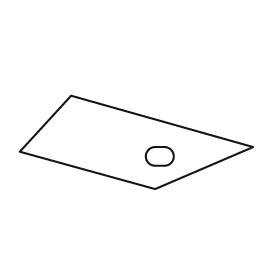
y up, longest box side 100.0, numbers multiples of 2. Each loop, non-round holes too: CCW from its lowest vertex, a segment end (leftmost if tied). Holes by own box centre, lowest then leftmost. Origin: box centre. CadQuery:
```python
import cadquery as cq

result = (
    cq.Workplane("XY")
    .moveTo(8.0, -20.0)
    .lineTo(50.0, -2.0)
    .lineTo(-28.0, 20.0)
    .lineTo(-50.0, -4.0)
    .close()
    .moveTo(8.0, -10.0)
    .lineTo(12.0, -10.0)
    .threePointArc((16.0, -6.0), (12.0, -2.0))
    .lineTo(8.0, -2.0)
    .threePointArc((4.0, -6.0), (8.0, -10.0))
    .close()
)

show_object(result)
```